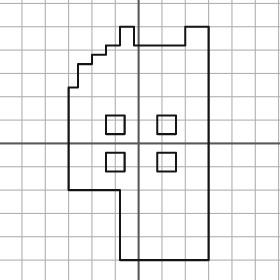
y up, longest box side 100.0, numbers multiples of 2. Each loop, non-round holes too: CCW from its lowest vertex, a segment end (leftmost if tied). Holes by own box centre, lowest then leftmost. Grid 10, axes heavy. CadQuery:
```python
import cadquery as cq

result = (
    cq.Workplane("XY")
    .moveTo(-8.0, -50.0)
    .lineTo(30.0, -50.0)
    .lineTo(30.0, 50.0)
    .lineTo(20.0, 50.0)
    .lineTo(20.0, 42.0)
    .lineTo(-2.0, 42.0)
    .lineTo(-2.0, 50.0)
    .lineTo(-8.0, 50.0)
    .lineTo(-8.0, 42.0)
    .lineTo(-14.0, 42.0)
    .lineTo(-14.0, 38.0)
    .lineTo(-20.0, 38.0)
    .lineTo(-20.0, 34.0)
    .lineTo(-26.0, 34.0)
    .lineTo(-26.0, 24.0)
    .lineTo(-30.0, 24.0)
    .lineTo(-30.0, -20.0)
    .lineTo(-8.0, -20.0)
    .close()
    .moveTo(-14.0, -12.0)
    .lineTo(-6.0, -12.0)
    .lineTo(-6.0, -4.0)
    .lineTo(-14.0, -4.0)
    .close()
    .moveTo(8.0, -12.0)
    .lineTo(16.0, -12.0)
    .lineTo(16.0, -4.0)
    .lineTo(8.0, -4.0)
    .close()
    .moveTo(-14.0, 4.0)
    .lineTo(-6.0, 4.0)
    .lineTo(-6.0, 12.0)
    .lineTo(-14.0, 12.0)
    .close()
    .moveTo(8.0, 4.0)
    .lineTo(16.0, 4.0)
    .lineTo(16.0, 12.0)
    .lineTo(8.0, 12.0)
    .close()
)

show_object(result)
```